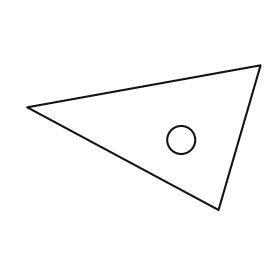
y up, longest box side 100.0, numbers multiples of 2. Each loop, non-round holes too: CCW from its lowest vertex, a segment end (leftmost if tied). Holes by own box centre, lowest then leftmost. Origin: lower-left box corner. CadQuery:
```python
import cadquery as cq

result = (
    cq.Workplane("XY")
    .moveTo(82.0, 0.0)
    .lineTo(100.0, 62.0)
    .lineTo(0.0, 44.0)
    .close()
    .moveTo(66.0, 30.0)
    .circle(6.0)
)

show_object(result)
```